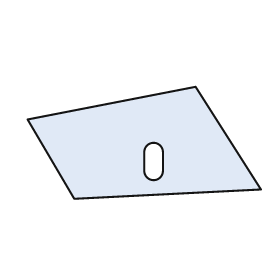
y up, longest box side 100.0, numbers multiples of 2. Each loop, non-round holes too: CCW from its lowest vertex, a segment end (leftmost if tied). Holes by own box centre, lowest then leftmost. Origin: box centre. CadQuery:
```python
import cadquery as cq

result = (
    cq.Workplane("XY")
    .moveTo(-30.0, -24.0)
    .lineTo(50.0, -20.0)
    .lineTo(22.0, 24.0)
    .lineTo(-50.0, 10.0)
    .close()
    .moveTo(0.0, -12.0)
    .threePointArc((4.0, -16.0), (8.0, -12.0))
    .lineTo(8.0, -4.0)
    .threePointArc((4.0, 0.0), (0.0, -4.0))
    .close()
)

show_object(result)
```